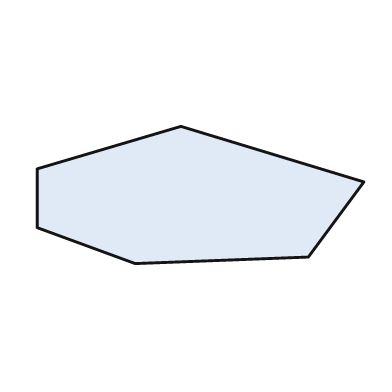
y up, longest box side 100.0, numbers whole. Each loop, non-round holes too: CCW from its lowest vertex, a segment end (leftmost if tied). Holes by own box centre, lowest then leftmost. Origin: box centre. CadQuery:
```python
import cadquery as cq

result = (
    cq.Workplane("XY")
    .moveTo(-20.0, -21.0)
    .lineTo(33.0, -19.0)
    .lineTo(50.0, 4.0)
    .lineTo(-6.0, 21.0)
    .lineTo(-50.0, 8.0)
    .lineTo(-50.0, -10.0)
    .close()
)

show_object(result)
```